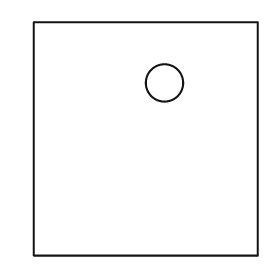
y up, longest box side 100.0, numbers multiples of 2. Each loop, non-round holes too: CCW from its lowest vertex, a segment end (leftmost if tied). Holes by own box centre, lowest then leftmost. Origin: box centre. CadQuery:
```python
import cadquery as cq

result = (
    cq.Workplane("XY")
    .moveTo(-48.0, -50.0)
    .lineTo(48.0, -50.0)
    .lineTo(48.0, 50.0)
    .lineTo(-48.0, 50.0)
    .close()
    .moveTo(8.0, 24.0)
    .circle(8.0)
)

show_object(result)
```